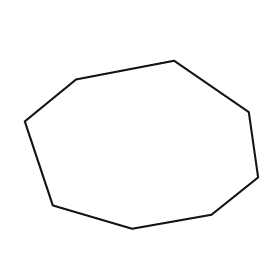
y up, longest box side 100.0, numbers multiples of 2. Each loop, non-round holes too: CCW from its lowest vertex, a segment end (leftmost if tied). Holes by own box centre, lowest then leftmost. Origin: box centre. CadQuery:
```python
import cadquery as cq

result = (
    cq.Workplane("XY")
    .moveTo(-4.0, -36.0)
    .lineTo(30.0, -30.0)
    .lineTo(50.0, -14.0)
    .lineTo(46.0, 14.0)
    .lineTo(14.0, 36.0)
    .lineTo(-28.0, 28.0)
    .lineTo(-50.0, 10.0)
    .lineTo(-38.0, -26.0)
    .close()
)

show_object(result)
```